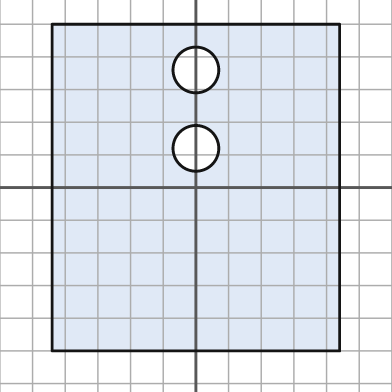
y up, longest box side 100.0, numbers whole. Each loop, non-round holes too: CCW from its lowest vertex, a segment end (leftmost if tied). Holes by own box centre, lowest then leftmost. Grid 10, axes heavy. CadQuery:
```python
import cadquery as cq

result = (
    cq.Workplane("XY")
    .moveTo(-44.0, -50.0)
    .lineTo(44.0, -50.0)
    .lineTo(44.0, 50.0)
    .lineTo(-44.0, 50.0)
    .close()
    .moveTo(0.0, 12.0)
    .circle(7.0)
    .moveTo(0.0, 36.0)
    .circle(7.0)
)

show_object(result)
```